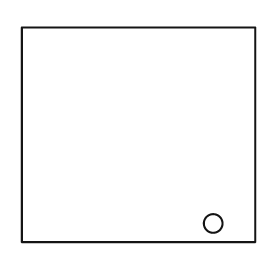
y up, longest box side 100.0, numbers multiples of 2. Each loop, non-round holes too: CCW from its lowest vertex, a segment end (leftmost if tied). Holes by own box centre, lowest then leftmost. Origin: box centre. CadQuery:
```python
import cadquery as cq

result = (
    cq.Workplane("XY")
    .moveTo(-50.0, -46.0)
    .lineTo(50.0, -46.0)
    .lineTo(50.0, 46.0)
    .lineTo(-50.0, 46.0)
    .close()
    .moveTo(32.0, -38.0)
    .circle(4.0)
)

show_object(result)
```